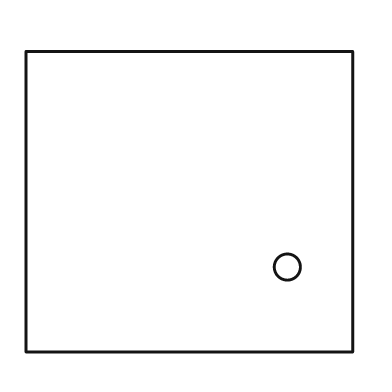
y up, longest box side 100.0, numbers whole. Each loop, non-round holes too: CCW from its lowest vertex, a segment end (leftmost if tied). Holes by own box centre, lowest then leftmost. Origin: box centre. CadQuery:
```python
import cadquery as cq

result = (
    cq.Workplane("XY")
    .moveTo(-50.0, -46.0)
    .lineTo(50.0, -46.0)
    .lineTo(50.0, 46.0)
    .lineTo(-50.0, 46.0)
    .close()
    .moveTo(30.0, -20.0)
    .circle(4.0)
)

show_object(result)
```